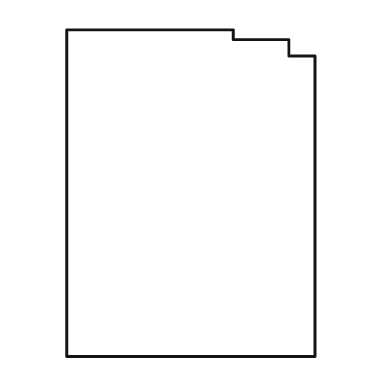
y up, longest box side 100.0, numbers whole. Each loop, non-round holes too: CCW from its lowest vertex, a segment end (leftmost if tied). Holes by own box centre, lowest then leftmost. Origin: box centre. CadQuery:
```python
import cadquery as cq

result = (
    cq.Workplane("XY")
    .moveTo(-38.0, -50.0)
    .lineTo(38.0, -50.0)
    .lineTo(38.0, 42.0)
    .lineTo(30.0, 42.0)
    .lineTo(30.0, 47.0)
    .lineTo(13.0, 47.0)
    .lineTo(13.0, 50.0)
    .lineTo(-38.0, 50.0)
    .close()
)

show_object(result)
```